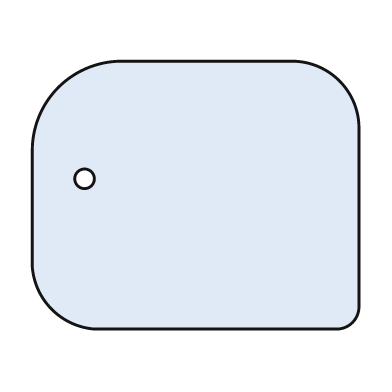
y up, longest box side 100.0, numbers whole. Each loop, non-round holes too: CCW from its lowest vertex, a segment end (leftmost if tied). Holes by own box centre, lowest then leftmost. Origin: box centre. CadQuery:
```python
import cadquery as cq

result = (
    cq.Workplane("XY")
    .moveTo(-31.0, -41.0)
    .lineTo(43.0, -41.0)
    .threePointArc((48.0, -39.0), (50.0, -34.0))
    .lineTo(50.0, 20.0)
    .threePointArc((44.0, 35.0), (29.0, 41.0))
    .lineTo(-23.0, 41.0)
    .threePointArc((-42.0, 33.0), (-50.0, 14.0))
    .lineTo(-50.0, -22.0)
    .threePointArc((-44.0, -35.0), (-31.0, -41.0))
    .close()
    .moveTo(-34.0, 5.0)
    .circle(3.0)
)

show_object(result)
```